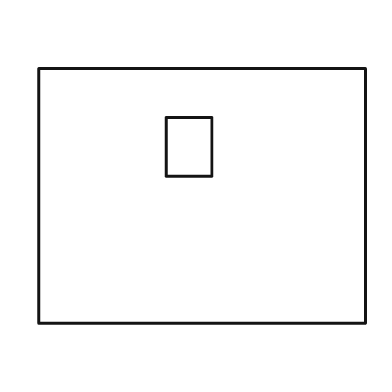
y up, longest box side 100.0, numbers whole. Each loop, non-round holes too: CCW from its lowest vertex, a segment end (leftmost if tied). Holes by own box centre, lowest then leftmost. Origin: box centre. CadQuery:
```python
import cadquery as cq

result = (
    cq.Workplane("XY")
    .moveTo(-50.0, -39.0)
    .lineTo(50.0, -39.0)
    .lineTo(50.0, 39.0)
    .lineTo(-50.0, 39.0)
    .close()
    .moveTo(-11.0, 6.0)
    .lineTo(3.0, 6.0)
    .lineTo(3.0, 24.0)
    .lineTo(-11.0, 24.0)
    .close()
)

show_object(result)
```